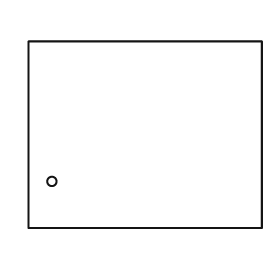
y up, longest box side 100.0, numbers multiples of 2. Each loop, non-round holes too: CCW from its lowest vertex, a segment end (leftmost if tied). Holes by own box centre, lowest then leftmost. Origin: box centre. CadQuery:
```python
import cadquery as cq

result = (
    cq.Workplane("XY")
    .moveTo(-50.0, -40.0)
    .lineTo(50.0, -40.0)
    .lineTo(50.0, 40.0)
    .lineTo(-50.0, 40.0)
    .close()
    .moveTo(-40.0, -20.0)
    .circle(2.0)
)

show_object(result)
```